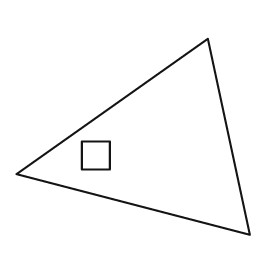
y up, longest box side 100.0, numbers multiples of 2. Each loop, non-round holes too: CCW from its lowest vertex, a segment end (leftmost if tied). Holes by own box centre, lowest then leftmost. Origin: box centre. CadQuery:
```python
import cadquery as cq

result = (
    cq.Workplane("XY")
    .moveTo(50.0, -42.0)
    .lineTo(32.0, 42.0)
    .lineTo(-50.0, -16.0)
    .close()
    .moveTo(-22.0, -14.0)
    .lineTo(-10.0, -14.0)
    .lineTo(-10.0, -2.0)
    .lineTo(-22.0, -2.0)
    .close()
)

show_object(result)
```